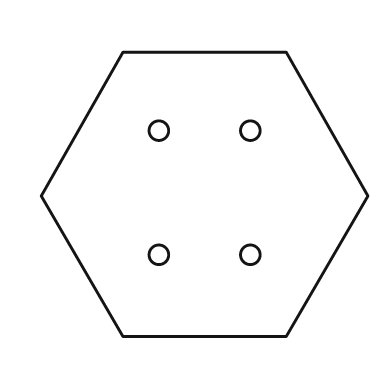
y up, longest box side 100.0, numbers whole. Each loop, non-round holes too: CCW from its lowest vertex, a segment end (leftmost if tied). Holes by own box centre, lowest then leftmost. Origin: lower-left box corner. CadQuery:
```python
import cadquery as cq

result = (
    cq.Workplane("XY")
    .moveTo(25.0, 0.0)
    .lineTo(75.0, 0.0)
    .lineTo(100.0, 43.0)
    .lineTo(75.0, 87.0)
    .lineTo(25.0, 87.0)
    .lineTo(0.0, 43.0)
    .close()
    .moveTo(36.0, 25.0)
    .circle(3.0)
    .moveTo(64.0, 25.0)
    .circle(3.0)
    .moveTo(36.0, 63.0)
    .circle(3.0)
    .moveTo(64.0, 63.0)
    .circle(3.0)
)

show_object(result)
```